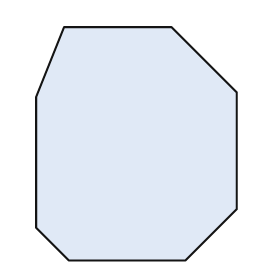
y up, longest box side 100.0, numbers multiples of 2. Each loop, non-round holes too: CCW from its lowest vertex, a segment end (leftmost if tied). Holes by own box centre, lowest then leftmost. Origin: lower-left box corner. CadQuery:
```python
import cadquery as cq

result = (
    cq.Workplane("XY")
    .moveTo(14.0, 0.0)
    .lineTo(64.0, 0.0)
    .lineTo(86.0, 22.0)
    .lineTo(86.0, 72.0)
    .lineTo(58.0, 100.0)
    .lineTo(12.0, 100.0)
    .lineTo(0.0, 70.0)
    .lineTo(0.0, 14.0)
    .close()
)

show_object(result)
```